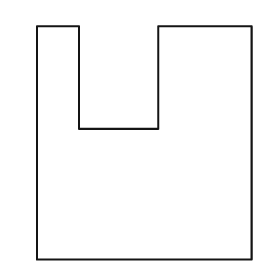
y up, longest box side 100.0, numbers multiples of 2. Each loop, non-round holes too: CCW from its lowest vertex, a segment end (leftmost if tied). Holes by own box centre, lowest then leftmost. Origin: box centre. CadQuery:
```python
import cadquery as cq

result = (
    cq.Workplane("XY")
    .moveTo(-46.0, -50.0)
    .lineTo(46.0, -50.0)
    .lineTo(46.0, 50.0)
    .lineTo(6.0, 50.0)
    .lineTo(6.0, 6.0)
    .lineTo(-28.0, 6.0)
    .lineTo(-28.0, 50.0)
    .lineTo(-46.0, 50.0)
    .close()
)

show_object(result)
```